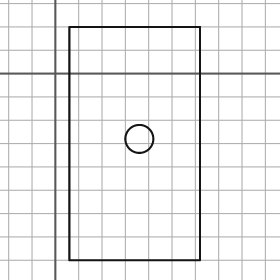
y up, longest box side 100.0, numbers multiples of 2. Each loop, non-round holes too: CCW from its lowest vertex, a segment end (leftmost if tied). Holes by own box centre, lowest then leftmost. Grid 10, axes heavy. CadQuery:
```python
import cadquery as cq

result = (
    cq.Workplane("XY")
    .moveTo(6.0, -80.0)
    .lineTo(62.0, -80.0)
    .lineTo(62.0, 20.0)
    .lineTo(6.0, 20.0)
    .close()
    .moveTo(36.0, -28.0)
    .circle(6.0)
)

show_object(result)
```